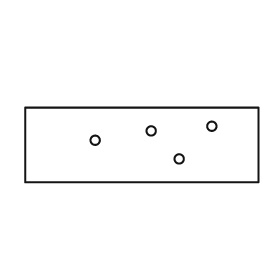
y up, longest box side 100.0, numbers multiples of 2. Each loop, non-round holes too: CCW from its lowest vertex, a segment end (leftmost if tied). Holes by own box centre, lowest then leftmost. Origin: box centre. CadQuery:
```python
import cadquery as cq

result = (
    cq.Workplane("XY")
    .moveTo(-50.0, -16.0)
    .lineTo(50.0, -16.0)
    .lineTo(50.0, 16.0)
    .lineTo(-50.0, 16.0)
    .close()
    .moveTo(16.0, -6.0)
    .circle(2.0)
    .moveTo(-20.0, 2.0)
    .circle(2.0)
    .moveTo(4.0, 6.0)
    .circle(2.0)
    .moveTo(30.0, 8.0)
    .circle(2.0)
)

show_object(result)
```